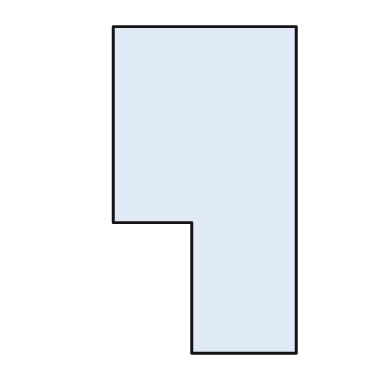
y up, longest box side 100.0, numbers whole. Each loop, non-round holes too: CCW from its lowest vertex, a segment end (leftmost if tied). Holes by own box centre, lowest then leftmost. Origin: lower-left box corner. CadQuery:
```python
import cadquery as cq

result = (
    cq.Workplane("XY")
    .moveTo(24.0, 0.0)
    .lineTo(56.0, 0.0)
    .lineTo(56.0, 100.0)
    .lineTo(0.0, 100.0)
    .lineTo(0.0, 40.0)
    .lineTo(24.0, 40.0)
    .close()
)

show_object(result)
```